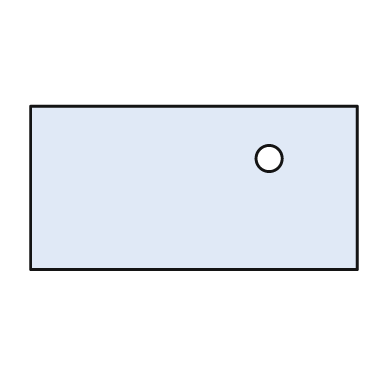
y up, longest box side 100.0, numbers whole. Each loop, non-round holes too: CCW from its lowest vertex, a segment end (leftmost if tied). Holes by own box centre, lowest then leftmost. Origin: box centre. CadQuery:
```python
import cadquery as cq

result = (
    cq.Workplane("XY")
    .moveTo(-50.0, -25.0)
    .lineTo(50.0, -25.0)
    .lineTo(50.0, 25.0)
    .lineTo(-50.0, 25.0)
    .close()
    .moveTo(23.0, 9.0)
    .circle(4.0)
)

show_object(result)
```